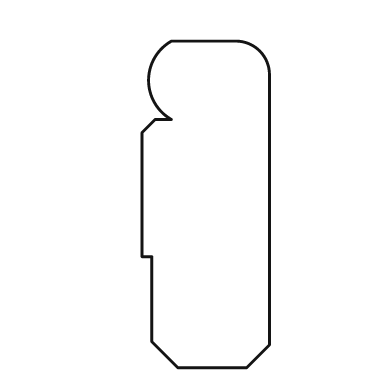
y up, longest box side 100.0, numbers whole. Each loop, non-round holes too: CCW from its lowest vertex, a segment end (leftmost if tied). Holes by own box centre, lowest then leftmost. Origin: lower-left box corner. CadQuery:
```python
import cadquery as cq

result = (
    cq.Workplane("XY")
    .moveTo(11.0, 0.0)
    .lineTo(32.0, 0.0)
    .lineTo(39.0, 7.0)
    .lineTo(39.0, 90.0)
    .threePointArc((36.0, 97.0), (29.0, 100.0))
    .lineTo(9.0, 100.0)
    .threePointArc((2.0, 88.0), (9.0, 76.0))
    .lineTo(4.0, 76.0)
    .lineTo(0.0, 72.0)
    .lineTo(0.0, 34.0)
    .lineTo(3.0, 34.0)
    .lineTo(3.0, 8.0)
    .close()
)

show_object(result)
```